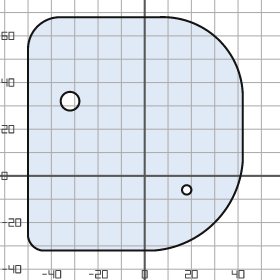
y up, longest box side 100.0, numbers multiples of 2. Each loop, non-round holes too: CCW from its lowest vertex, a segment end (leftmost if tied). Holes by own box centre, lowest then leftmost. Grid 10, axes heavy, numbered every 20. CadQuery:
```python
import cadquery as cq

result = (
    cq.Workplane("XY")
    .moveTo(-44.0, -32.0)
    .lineTo(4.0, -32.0)
    .threePointArc((30.0, -20.0), (42.0, 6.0))
    .lineTo(42.0, 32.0)
    .threePointArc((32.0, 58.0), (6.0, 68.0))
    .lineTo(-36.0, 68.0)
    .threePointArc((-46.0, 64.0), (-50.0, 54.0))
    .lineTo(-50.0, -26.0)
    .threePointArc((-48.0, -30.0), (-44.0, -32.0))
    .close()
    .moveTo(18.0, -6.0)
    .circle(2.0)
    .moveTo(-32.0, 32.0)
    .circle(4.0)
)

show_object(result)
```